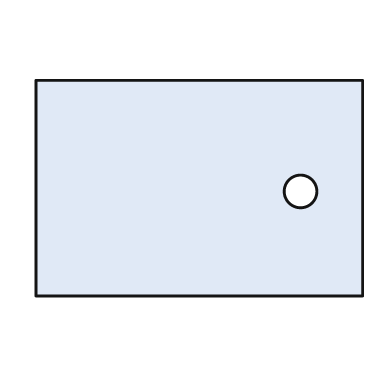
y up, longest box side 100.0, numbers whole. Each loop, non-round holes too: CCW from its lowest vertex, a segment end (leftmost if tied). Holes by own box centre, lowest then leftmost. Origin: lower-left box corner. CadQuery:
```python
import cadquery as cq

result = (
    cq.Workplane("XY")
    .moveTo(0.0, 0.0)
    .lineTo(100.0, 0.0)
    .lineTo(100.0, 66.0)
    .lineTo(0.0, 66.0)
    .close()
    .moveTo(81.0, 32.0)
    .circle(5.0)
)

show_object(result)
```